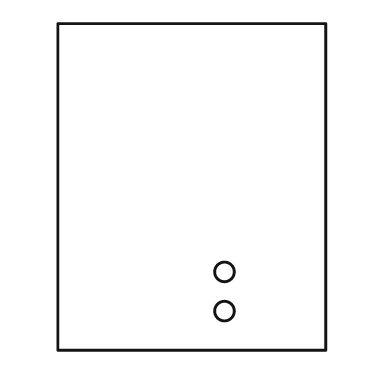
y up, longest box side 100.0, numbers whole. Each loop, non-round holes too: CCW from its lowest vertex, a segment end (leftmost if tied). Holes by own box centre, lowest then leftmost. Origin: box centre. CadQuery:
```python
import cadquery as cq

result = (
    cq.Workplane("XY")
    .moveTo(-41.0, -50.0)
    .lineTo(41.0, -50.0)
    .lineTo(41.0, 50.0)
    .lineTo(-41.0, 50.0)
    .close()
    .moveTo(10.0, -38.0)
    .circle(3.0)
    .moveTo(10.0, -26.0)
    .circle(3.0)
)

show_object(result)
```